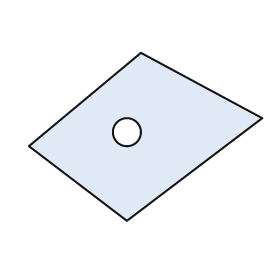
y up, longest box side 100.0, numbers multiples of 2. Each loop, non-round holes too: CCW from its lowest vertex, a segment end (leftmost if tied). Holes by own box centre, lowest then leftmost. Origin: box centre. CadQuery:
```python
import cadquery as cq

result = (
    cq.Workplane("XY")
    .moveTo(-8.0, -36.0)
    .lineTo(50.0, 8.0)
    .lineTo(-2.0, 36.0)
    .lineTo(-50.0, -4.0)
    .close()
    .moveTo(-8.0, 2.0)
    .circle(6.0)
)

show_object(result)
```